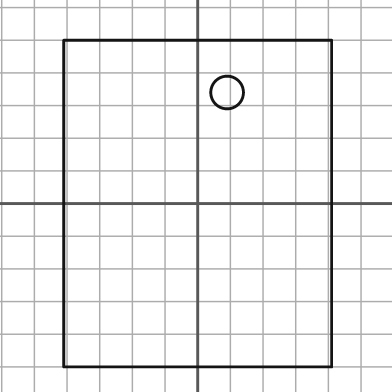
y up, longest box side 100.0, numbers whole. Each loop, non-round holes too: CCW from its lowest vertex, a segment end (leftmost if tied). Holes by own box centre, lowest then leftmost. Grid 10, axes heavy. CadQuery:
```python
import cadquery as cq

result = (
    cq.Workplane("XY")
    .moveTo(-41.0, -50.0)
    .lineTo(41.0, -50.0)
    .lineTo(41.0, 50.0)
    .lineTo(-41.0, 50.0)
    .close()
    .moveTo(9.0, 34.0)
    .circle(5.0)
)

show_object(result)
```